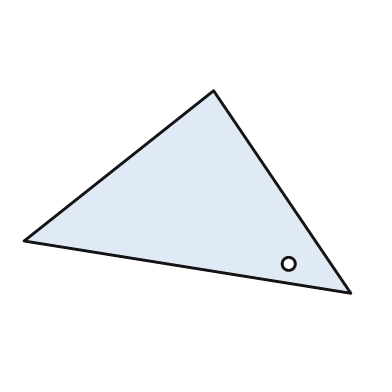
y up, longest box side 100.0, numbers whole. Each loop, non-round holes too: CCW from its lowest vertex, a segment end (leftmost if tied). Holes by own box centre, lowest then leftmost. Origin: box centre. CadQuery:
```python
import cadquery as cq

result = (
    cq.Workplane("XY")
    .moveTo(50.0, -31.0)
    .lineTo(8.0, 31.0)
    .lineTo(-50.0, -15.0)
    .close()
    .moveTo(31.0, -22.0)
    .circle(2.0)
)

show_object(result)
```